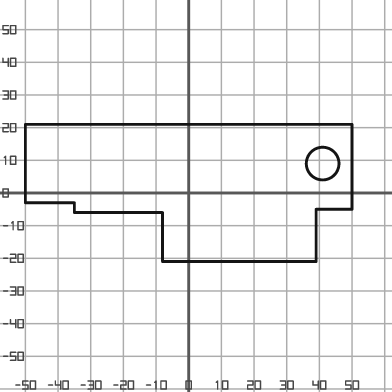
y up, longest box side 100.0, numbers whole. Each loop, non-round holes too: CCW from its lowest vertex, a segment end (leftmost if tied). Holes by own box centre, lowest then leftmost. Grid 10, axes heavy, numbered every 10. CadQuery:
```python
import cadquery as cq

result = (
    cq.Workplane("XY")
    .moveTo(-8.0, -21.0)
    .lineTo(39.0, -21.0)
    .lineTo(39.0, -5.0)
    .lineTo(50.0, -5.0)
    .lineTo(50.0, 21.0)
    .lineTo(-50.0, 21.0)
    .lineTo(-50.0, -3.0)
    .lineTo(-35.0, -3.0)
    .lineTo(-35.0, -6.0)
    .lineTo(-8.0, -6.0)
    .close()
    .moveTo(41.0, 9.0)
    .circle(5.0)
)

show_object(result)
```